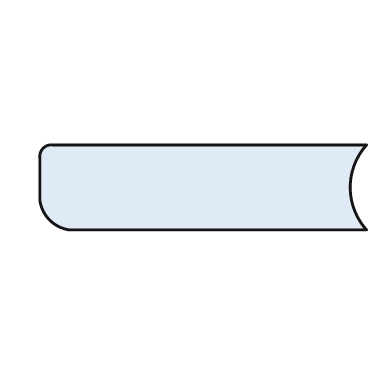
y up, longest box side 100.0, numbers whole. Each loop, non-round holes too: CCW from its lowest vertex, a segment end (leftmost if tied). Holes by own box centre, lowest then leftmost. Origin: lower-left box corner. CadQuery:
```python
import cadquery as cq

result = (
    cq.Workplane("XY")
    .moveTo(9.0, 0.0)
    .lineTo(100.0, 0.0)
    .threePointArc((95.0, 13.0), (100.0, 26.0))
    .lineTo(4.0, 26.0)
    .threePointArc((1.0, 25.0), (0.0, 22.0))
    .lineTo(0.0, 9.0)
    .threePointArc((3.0, 3.0), (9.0, 0.0))
    .close()
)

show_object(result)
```